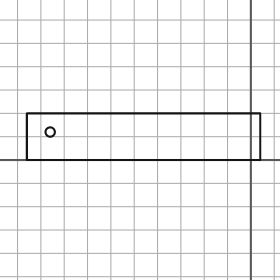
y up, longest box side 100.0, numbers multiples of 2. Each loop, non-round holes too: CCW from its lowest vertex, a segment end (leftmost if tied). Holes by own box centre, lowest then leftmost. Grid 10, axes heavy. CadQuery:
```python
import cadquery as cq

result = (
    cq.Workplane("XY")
    .moveTo(-96.0, 0.0)
    .lineTo(4.0, 0.0)
    .lineTo(4.0, 20.0)
    .lineTo(-96.0, 20.0)
    .close()
    .moveTo(-86.0, 12.0)
    .circle(2.0)
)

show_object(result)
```